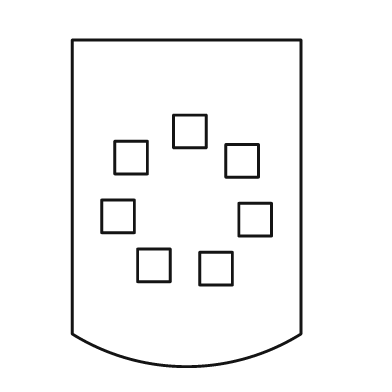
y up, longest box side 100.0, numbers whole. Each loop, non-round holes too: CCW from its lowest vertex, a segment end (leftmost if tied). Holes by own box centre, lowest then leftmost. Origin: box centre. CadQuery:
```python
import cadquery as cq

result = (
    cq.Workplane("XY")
    .moveTo(-35.0, -40.0)
    .threePointArc((0.0, -50.0), (35.0, -40.0))
    .lineTo(35.0, 50.0)
    .lineTo(-35.0, 50.0)
    .close()
    .moveTo(4.0, -25.0)
    .lineTo(14.0, -25.0)
    .lineTo(14.0, -15.0)
    .lineTo(4.0, -15.0)
    .close()
    .moveTo(-15.0, -24.0)
    .lineTo(-5.0, -24.0)
    .lineTo(-5.0, -14.0)
    .lineTo(-15.0, -14.0)
    .close()
    .moveTo(16.0, -10.0)
    .lineTo(26.0, -10.0)
    .lineTo(26.0, 0.0)
    .lineTo(16.0, 0.0)
    .close()
    .moveTo(-26.0, -9.0)
    .lineTo(-16.0, -9.0)
    .lineTo(-16.0, 1.0)
    .lineTo(-26.0, 1.0)
    .close()
    .moveTo(12.0, 8.0)
    .lineTo(22.0, 8.0)
    .lineTo(22.0, 18.0)
    .lineTo(12.0, 18.0)
    .close()
    .moveTo(-22.0, 9.0)
    .lineTo(-12.0, 9.0)
    .lineTo(-12.0, 19.0)
    .lineTo(-22.0, 19.0)
    .close()
    .moveTo(-4.0, 17.0)
    .lineTo(6.0, 17.0)
    .lineTo(6.0, 27.0)
    .lineTo(-4.0, 27.0)
    .close()
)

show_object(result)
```